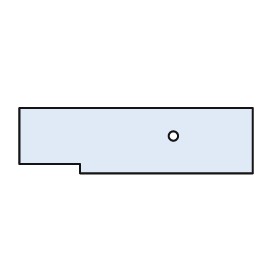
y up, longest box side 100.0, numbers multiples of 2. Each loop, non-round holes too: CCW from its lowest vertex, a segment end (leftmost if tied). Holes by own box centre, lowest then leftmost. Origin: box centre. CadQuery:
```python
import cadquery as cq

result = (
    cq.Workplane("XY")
    .moveTo(-24.0, -14.0)
    .lineTo(50.0, -14.0)
    .lineTo(50.0, 14.0)
    .lineTo(-50.0, 14.0)
    .lineTo(-50.0, -10.0)
    .lineTo(-24.0, -10.0)
    .close()
    .moveTo(16.0, 2.0)
    .circle(2.0)
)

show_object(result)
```